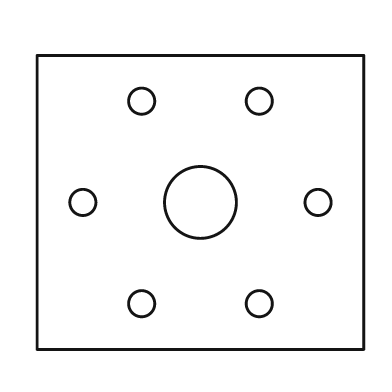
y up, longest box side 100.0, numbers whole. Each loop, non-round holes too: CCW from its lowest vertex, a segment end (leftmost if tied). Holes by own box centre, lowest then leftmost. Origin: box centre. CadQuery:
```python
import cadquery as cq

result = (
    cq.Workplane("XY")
    .moveTo(-50.0, -45.0)
    .lineTo(50.0, -45.0)
    .lineTo(50.0, 45.0)
    .lineTo(-50.0, 45.0)
    .close()
    .moveTo(-18.0, -31.0)
    .circle(4.0)
    .moveTo(18.0, -31.0)
    .circle(4.0)
    .moveTo(-36.0, 0.0)
    .circle(4.0)
    .moveTo(0.0, 0.0)
    .circle(11.0)
    .moveTo(36.0, 0.0)
    .circle(4.0)
    .moveTo(-18.0, 31.0)
    .circle(4.0)
    .moveTo(18.0, 31.0)
    .circle(4.0)
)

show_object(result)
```